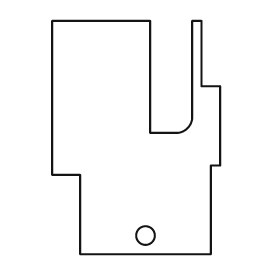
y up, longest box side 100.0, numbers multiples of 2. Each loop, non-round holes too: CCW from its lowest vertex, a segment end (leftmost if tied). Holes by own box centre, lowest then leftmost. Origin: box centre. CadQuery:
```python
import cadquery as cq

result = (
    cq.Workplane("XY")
    .moveTo(-24.0, -50.0)
    .lineTo(32.0, -50.0)
    .lineTo(32.0, -12.0)
    .lineTo(36.0, -12.0)
    .lineTo(36.0, 22.0)
    .lineTo(28.0, 22.0)
    .lineTo(28.0, 50.0)
    .lineTo(24.0, 50.0)
    .lineTo(24.0, 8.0)
    .threePointArc((22.0, 4.0), (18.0, 2.0))
    .lineTo(6.0, 2.0)
    .lineTo(6.0, 50.0)
    .lineTo(-36.0, 50.0)
    .lineTo(-36.0, -16.0)
    .lineTo(-24.0, -16.0)
    .close()
    .moveTo(4.0, -42.0)
    .circle(4.0)
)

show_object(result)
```